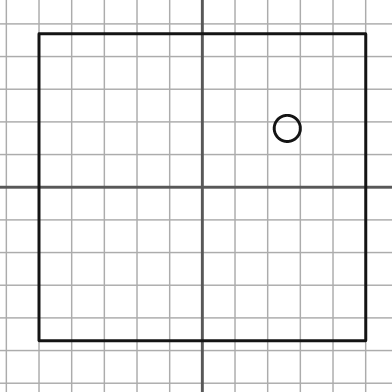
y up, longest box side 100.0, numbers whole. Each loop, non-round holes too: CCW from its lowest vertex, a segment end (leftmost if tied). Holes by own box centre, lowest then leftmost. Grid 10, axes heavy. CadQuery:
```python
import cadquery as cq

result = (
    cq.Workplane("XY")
    .moveTo(-50.0, -47.0)
    .lineTo(50.0, -47.0)
    .lineTo(50.0, 47.0)
    .lineTo(-50.0, 47.0)
    .close()
    .moveTo(26.0, 18.0)
    .circle(4.0)
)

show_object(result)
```